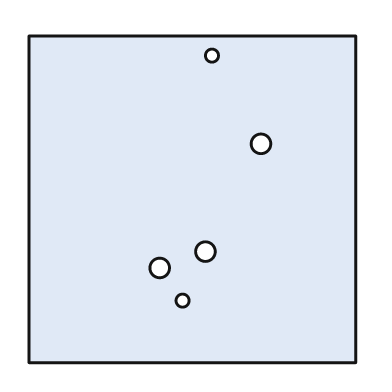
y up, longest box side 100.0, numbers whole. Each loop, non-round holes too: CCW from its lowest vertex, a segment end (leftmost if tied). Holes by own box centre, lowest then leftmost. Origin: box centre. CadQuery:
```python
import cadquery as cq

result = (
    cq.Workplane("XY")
    .moveTo(-50.0, -50.0)
    .lineTo(50.0, -50.0)
    .lineTo(50.0, 50.0)
    .lineTo(-50.0, 50.0)
    .close()
    .moveTo(-3.0, -31.0)
    .circle(2.0)
    .moveTo(-10.0, -21.0)
    .circle(3.0)
    .moveTo(4.0, -16.0)
    .circle(3.0)
    .moveTo(21.0, 17.0)
    .circle(3.0)
    .moveTo(6.0, 44.0)
    .circle(2.0)
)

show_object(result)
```